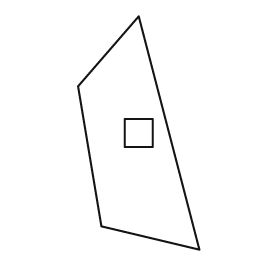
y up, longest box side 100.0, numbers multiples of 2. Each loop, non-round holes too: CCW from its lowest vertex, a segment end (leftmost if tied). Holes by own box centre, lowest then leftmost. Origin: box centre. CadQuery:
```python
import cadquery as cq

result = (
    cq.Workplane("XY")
    .moveTo(26.0, -50.0)
    .lineTo(0.0, 50.0)
    .lineTo(-26.0, 20.0)
    .lineTo(-16.0, -40.0)
    .close()
    .moveTo(-6.0, -6.0)
    .lineTo(6.0, -6.0)
    .lineTo(6.0, 6.0)
    .lineTo(-6.0, 6.0)
    .close()
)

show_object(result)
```